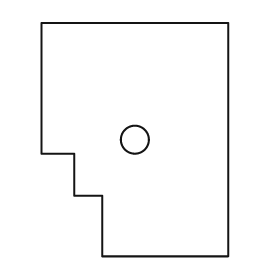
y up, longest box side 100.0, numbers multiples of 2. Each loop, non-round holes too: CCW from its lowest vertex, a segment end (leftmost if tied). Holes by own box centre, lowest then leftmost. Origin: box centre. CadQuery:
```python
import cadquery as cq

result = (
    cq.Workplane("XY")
    .moveTo(-14.0, -50.0)
    .lineTo(40.0, -50.0)
    .lineTo(40.0, 50.0)
    .lineTo(-40.0, 50.0)
    .lineTo(-40.0, -6.0)
    .lineTo(-26.0, -6.0)
    .lineTo(-26.0, -24.0)
    .lineTo(-14.0, -24.0)
    .close()
    .moveTo(0.0, 0.0)
    .circle(6.0)
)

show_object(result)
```